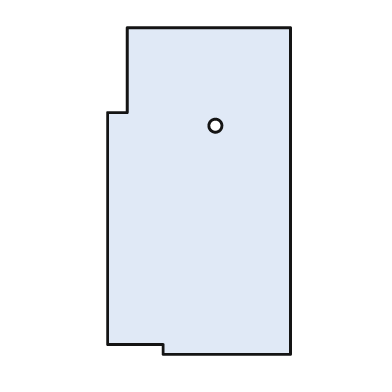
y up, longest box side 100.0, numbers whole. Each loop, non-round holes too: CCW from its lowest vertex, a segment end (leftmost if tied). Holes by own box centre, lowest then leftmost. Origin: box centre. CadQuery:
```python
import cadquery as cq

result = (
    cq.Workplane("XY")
    .moveTo(-11.0, -50.0)
    .lineTo(28.0, -50.0)
    .lineTo(28.0, 50.0)
    .lineTo(-22.0, 50.0)
    .lineTo(-22.0, 24.0)
    .lineTo(-28.0, 24.0)
    .lineTo(-28.0, -47.0)
    .lineTo(-11.0, -47.0)
    .close()
    .moveTo(5.0, 20.0)
    .circle(2.0)
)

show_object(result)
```